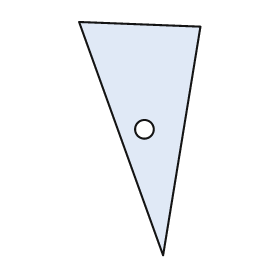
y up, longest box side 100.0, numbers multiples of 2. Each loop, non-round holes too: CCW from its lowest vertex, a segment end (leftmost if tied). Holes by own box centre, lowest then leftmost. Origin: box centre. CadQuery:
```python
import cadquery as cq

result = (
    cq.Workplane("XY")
    .moveTo(10.0, -50.0)
    .lineTo(26.0, 48.0)
    .lineTo(-26.0, 50.0)
    .close()
    .moveTo(2.0, 4.0)
    .circle(4.0)
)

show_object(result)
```